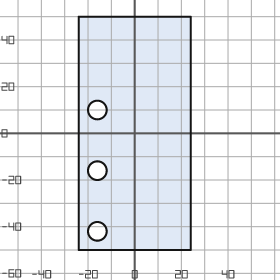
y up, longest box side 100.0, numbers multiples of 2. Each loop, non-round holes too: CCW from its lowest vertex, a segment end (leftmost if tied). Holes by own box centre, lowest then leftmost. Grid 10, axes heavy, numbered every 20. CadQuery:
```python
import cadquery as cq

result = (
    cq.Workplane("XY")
    .moveTo(-24.0, -50.0)
    .lineTo(24.0, -50.0)
    .lineTo(24.0, 50.0)
    .lineTo(-24.0, 50.0)
    .close()
    .moveTo(-16.0, -42.0)
    .circle(4.0)
    .moveTo(-16.0, -16.0)
    .circle(4.0)
    .moveTo(-16.0, 10.0)
    .circle(4.0)
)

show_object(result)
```